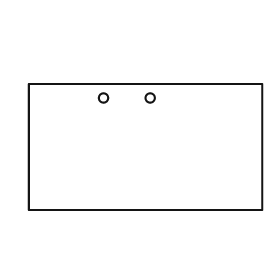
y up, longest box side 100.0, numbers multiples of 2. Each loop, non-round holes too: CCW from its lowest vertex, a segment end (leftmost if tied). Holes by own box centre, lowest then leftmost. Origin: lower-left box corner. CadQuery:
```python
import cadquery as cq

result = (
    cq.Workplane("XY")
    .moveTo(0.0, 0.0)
    .lineTo(100.0, 0.0)
    .lineTo(100.0, 54.0)
    .lineTo(0.0, 54.0)
    .close()
    .moveTo(32.0, 48.0)
    .circle(2.0)
    .moveTo(52.0, 48.0)
    .circle(2.0)
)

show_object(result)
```